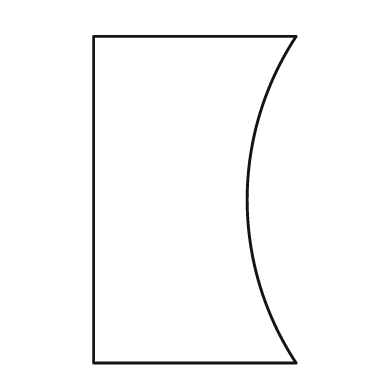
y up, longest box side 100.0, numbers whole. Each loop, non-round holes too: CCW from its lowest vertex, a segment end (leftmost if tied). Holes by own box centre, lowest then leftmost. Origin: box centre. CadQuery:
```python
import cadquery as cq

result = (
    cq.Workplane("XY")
    .moveTo(-31.0, -50.0)
    .lineTo(31.0, -50.0)
    .threePointArc((16.0, 0.0), (31.0, 50.0))
    .lineTo(-31.0, 50.0)
    .close()
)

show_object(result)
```